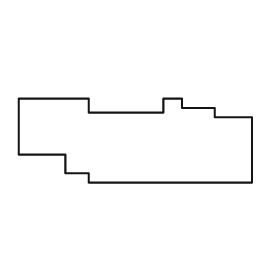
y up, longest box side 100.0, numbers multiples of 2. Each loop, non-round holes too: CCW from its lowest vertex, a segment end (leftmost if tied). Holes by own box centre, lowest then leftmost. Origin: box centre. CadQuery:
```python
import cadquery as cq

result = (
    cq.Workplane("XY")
    .moveTo(-20.0, -18.0)
    .lineTo(50.0, -18.0)
    .lineTo(50.0, 10.0)
    .lineTo(34.0, 10.0)
    .lineTo(34.0, 14.0)
    .lineTo(20.0, 14.0)
    .lineTo(20.0, 18.0)
    .lineTo(12.0, 18.0)
    .lineTo(12.0, 12.0)
    .lineTo(-20.0, 12.0)
    .lineTo(-20.0, 18.0)
    .lineTo(-50.0, 18.0)
    .lineTo(-50.0, -6.0)
    .lineTo(-30.0, -6.0)
    .lineTo(-30.0, -14.0)
    .lineTo(-20.0, -14.0)
    .close()
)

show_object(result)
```